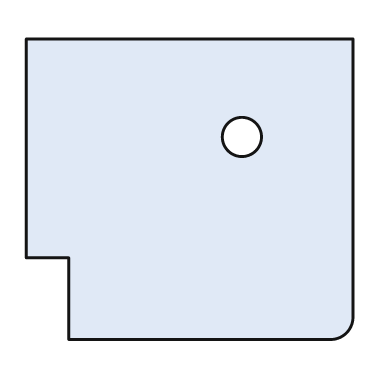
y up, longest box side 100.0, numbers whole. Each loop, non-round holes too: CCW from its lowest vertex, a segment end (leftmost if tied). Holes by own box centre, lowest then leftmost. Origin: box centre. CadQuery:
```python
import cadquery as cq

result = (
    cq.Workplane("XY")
    .moveTo(-37.0, -46.0)
    .lineTo(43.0, -46.0)
    .threePointArc((48.0, -44.0), (50.0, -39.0))
    .lineTo(50.0, 46.0)
    .lineTo(-50.0, 46.0)
    .lineTo(-50.0, -21.0)
    .lineTo(-37.0, -21.0)
    .close()
    .moveTo(16.0, 16.0)
    .circle(6.0)
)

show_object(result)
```